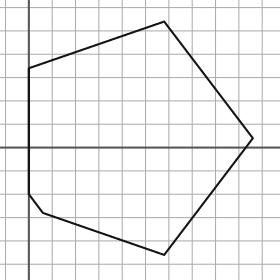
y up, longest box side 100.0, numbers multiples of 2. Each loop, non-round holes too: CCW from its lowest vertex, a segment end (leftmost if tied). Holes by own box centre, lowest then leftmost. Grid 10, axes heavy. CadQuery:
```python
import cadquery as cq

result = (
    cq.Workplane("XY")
    .moveTo(58.0, -46.0)
    .lineTo(96.0, 4.0)
    .lineTo(58.0, 54.0)
    .lineTo(0.0, 34.0)
    .lineTo(0.0, -20.0)
    .lineTo(6.0, -28.0)
    .close()
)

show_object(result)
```